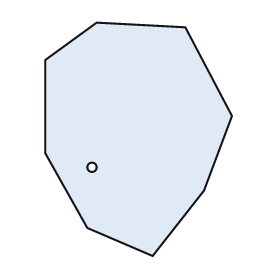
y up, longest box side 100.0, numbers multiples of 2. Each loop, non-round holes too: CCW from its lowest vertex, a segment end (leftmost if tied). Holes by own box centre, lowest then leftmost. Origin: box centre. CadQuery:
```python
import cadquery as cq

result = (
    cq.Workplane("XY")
    .moveTo(6.0, -50.0)
    .lineTo(28.0, -22.0)
    .lineTo(40.0, 10.0)
    .lineTo(20.0, 48.0)
    .lineTo(-18.0, 50.0)
    .lineTo(-40.0, 34.0)
    .lineTo(-40.0, -6.0)
    .lineTo(-22.0, -38.0)
    .close()
    .moveTo(-20.0, -12.0)
    .circle(2.0)
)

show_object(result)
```